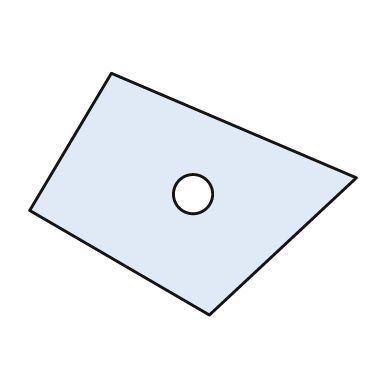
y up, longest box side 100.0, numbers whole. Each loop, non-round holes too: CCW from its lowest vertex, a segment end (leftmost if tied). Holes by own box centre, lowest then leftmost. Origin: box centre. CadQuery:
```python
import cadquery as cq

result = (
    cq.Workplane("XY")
    .moveTo(5.0, -37.0)
    .lineTo(50.0, 5.0)
    .lineTo(-25.0, 37.0)
    .lineTo(-50.0, -5.0)
    .close()
    .moveTo(0.0, 0.0)
    .circle(6.0)
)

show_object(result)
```